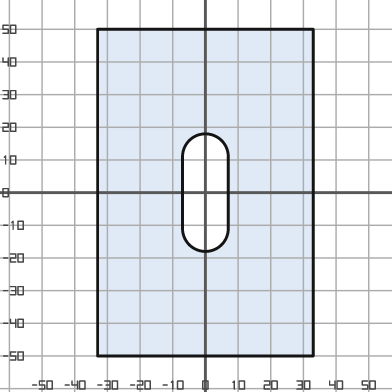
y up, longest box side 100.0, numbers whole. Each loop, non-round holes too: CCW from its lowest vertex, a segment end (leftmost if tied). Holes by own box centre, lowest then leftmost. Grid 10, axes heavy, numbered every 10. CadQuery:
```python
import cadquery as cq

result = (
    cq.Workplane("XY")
    .moveTo(-33.0, -50.0)
    .lineTo(33.0, -50.0)
    .lineTo(33.0, 50.0)
    .lineTo(-33.0, 50.0)
    .close()
    .moveTo(-7.0, -11.0)
    .threePointArc((0.0, -18.0), (7.0, -11.0))
    .lineTo(7.0, 11.0)
    .threePointArc((0.0, 18.0), (-7.0, 11.0))
    .close()
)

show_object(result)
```